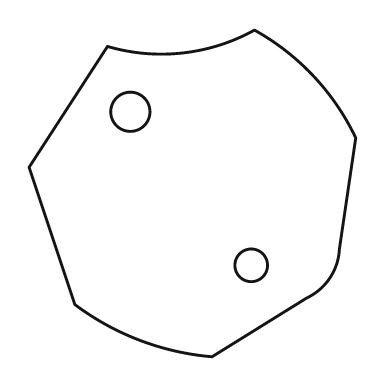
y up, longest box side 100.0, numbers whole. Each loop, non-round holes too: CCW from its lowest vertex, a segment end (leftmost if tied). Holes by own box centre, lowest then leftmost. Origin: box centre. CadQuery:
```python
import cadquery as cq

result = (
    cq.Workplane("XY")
    .moveTo(6.0, -50.0)
    .lineTo(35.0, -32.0)
    .threePointArc((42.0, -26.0), (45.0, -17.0))
    .lineTo(50.0, 17.0)
    .threePointArc((37.0, 36.0), (19.0, 50.0))
    .threePointArc((-3.0, 43.0), (-26.0, 45.0))
    .lineTo(-50.0, 8.0)
    .lineTo(-36.0, -34.0)
    .threePointArc((-16.0, -45.0), (6.0, -50.0))
    .close()
    .moveTo(18.0, -22.0)
    .circle(5.0)
    .moveTo(-19.0, 25.0)
    .circle(6.0)
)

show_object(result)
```